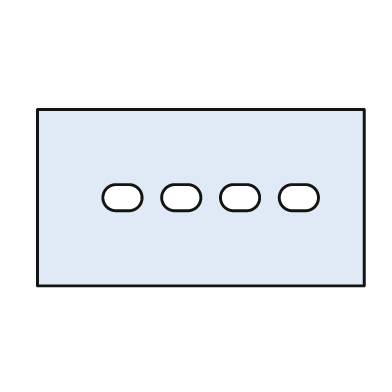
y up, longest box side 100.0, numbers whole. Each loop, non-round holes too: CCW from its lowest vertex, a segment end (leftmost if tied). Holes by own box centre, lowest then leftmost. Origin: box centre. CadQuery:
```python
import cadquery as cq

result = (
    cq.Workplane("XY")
    .moveTo(-50.0, -27.0)
    .lineTo(50.0, -27.0)
    .lineTo(50.0, 27.0)
    .lineTo(-50.0, 27.0)
    .close()
    .moveTo(-26.0, -4.0)
    .lineTo(-22.0, -4.0)
    .threePointArc((-18.0, 0.0), (-22.0, 4.0))
    .lineTo(-26.0, 4.0)
    .threePointArc((-30.0, 0.0), (-26.0, -4.0))
    .close()
    .moveTo(-8.0, -4.0)
    .lineTo(-4.0, -4.0)
    .threePointArc((0.0, 0.0), (-4.0, 4.0))
    .lineTo(-8.0, 4.0)
    .threePointArc((-12.0, 0.0), (-8.0, -4.0))
    .close()
    .moveTo(10.0, -4.0)
    .lineTo(14.0, -4.0)
    .threePointArc((18.0, 0.0), (14.0, 4.0))
    .lineTo(10.0, 4.0)
    .threePointArc((6.0, 0.0), (10.0, -4.0))
    .close()
    .moveTo(28.0, -4.0)
    .lineTo(32.0, -4.0)
    .threePointArc((36.0, 0.0), (32.0, 4.0))
    .lineTo(28.0, 4.0)
    .threePointArc((24.0, 0.0), (28.0, -4.0))
    .close()
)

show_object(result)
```